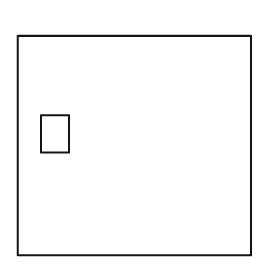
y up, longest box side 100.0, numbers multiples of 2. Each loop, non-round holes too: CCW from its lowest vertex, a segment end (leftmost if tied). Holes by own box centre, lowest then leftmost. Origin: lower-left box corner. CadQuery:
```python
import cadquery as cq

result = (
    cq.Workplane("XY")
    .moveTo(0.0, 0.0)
    .lineTo(100.0, 0.0)
    .lineTo(100.0, 94.0)
    .lineTo(0.0, 94.0)
    .close()
    .moveTo(10.0, 44.0)
    .lineTo(22.0, 44.0)
    .lineTo(22.0, 60.0)
    .lineTo(10.0, 60.0)
    .close()
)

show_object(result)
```